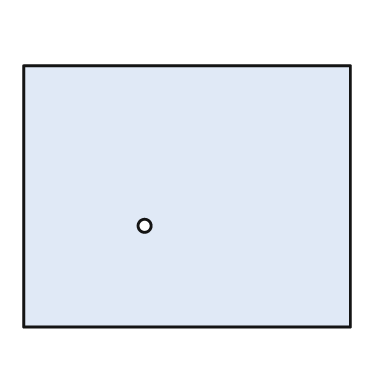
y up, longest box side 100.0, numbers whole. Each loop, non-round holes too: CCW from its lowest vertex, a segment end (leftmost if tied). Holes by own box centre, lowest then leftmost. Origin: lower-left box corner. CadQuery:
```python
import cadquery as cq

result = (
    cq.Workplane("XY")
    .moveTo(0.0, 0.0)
    .lineTo(100.0, 0.0)
    .lineTo(100.0, 80.0)
    .lineTo(0.0, 80.0)
    .close()
    .moveTo(37.0, 31.0)
    .circle(2.0)
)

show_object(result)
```